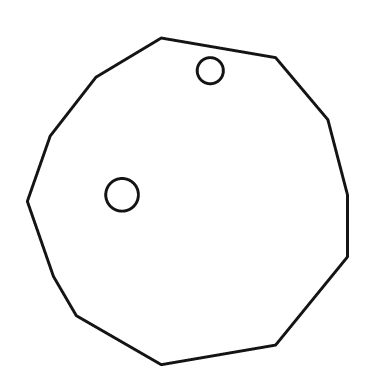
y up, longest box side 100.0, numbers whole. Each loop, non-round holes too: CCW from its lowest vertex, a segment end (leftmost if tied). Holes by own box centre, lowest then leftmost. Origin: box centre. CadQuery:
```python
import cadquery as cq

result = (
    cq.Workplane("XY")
    .moveTo(-8.0, -50.0)
    .lineTo(27.0, -44.0)
    .lineTo(49.0, -17.0)
    .lineTo(49.0, 2.0)
    .lineTo(43.0, 25.0)
    .lineTo(27.0, 44.0)
    .lineTo(-8.0, 50.0)
    .lineTo(-28.0, 38.0)
    .lineTo(-42.0, 20.0)
    .lineTo(-49.0, 0.0)
    .lineTo(-41.0, -23.0)
    .lineTo(-34.0, -35.0)
    .close()
    .moveTo(-20.0, 2.0)
    .circle(5.0)
    .moveTo(7.0, 40.0)
    .circle(4.0)
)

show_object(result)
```